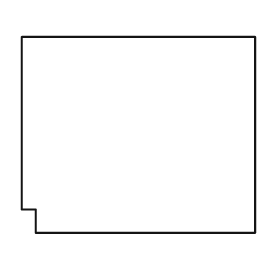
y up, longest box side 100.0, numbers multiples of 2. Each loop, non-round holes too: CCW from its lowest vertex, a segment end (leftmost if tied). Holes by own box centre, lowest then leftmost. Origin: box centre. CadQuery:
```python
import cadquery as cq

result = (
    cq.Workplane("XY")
    .moveTo(-44.0, -42.0)
    .lineTo(50.0, -42.0)
    .lineTo(50.0, 42.0)
    .lineTo(-50.0, 42.0)
    .lineTo(-50.0, -32.0)
    .lineTo(-44.0, -32.0)
    .close()
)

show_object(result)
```